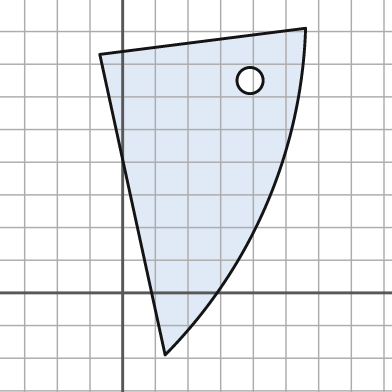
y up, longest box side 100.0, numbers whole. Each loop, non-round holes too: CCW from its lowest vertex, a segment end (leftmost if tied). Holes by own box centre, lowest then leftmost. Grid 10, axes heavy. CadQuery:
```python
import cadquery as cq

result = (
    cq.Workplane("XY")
    .moveTo(13.0, -19.0)
    .threePointArc((44.0, 27.0), (56.0, 81.0))
    .lineTo(-7.0, 73.0)
    .close()
    .moveTo(39.0, 65.0)
    .circle(4.0)
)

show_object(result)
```